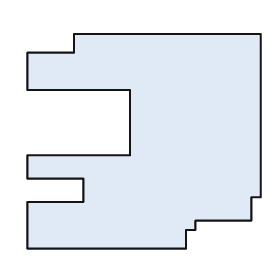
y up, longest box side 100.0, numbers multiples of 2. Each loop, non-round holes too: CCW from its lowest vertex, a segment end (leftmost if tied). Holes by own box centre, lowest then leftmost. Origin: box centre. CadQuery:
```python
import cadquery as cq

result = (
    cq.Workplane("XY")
    .moveTo(-50.0, -46.0)
    .lineTo(18.0, -46.0)
    .lineTo(18.0, -38.0)
    .lineTo(22.0, -38.0)
    .lineTo(22.0, -34.0)
    .lineTo(46.0, -34.0)
    .lineTo(46.0, -24.0)
    .lineTo(50.0, -24.0)
    .lineTo(50.0, 46.0)
    .lineTo(-30.0, 46.0)
    .lineTo(-30.0, 38.0)
    .lineTo(-50.0, 38.0)
    .lineTo(-50.0, 22.0)
    .lineTo(-6.0, 22.0)
    .lineTo(-6.0, -6.0)
    .lineTo(-50.0, -6.0)
    .lineTo(-50.0, -16.0)
    .lineTo(-26.0, -16.0)
    .lineTo(-26.0, -26.0)
    .lineTo(-50.0, -26.0)
    .close()
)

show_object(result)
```